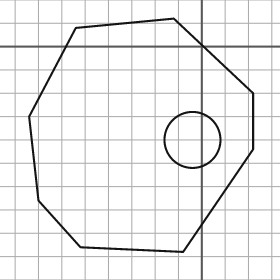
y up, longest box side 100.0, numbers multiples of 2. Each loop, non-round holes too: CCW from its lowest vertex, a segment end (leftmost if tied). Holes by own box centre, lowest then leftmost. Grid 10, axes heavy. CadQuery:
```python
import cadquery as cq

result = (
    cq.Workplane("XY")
    .moveTo(-8.0, -88.0)
    .lineTo(22.0, -44.0)
    .lineTo(22.0, -20.0)
    .lineTo(-12.0, 12.0)
    .lineTo(-54.0, 8.0)
    .lineTo(-74.0, -30.0)
    .lineTo(-70.0, -66.0)
    .lineTo(-52.0, -86.0)
    .close()
    .moveTo(-4.0, -40.0)
    .circle(12.0)
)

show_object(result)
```